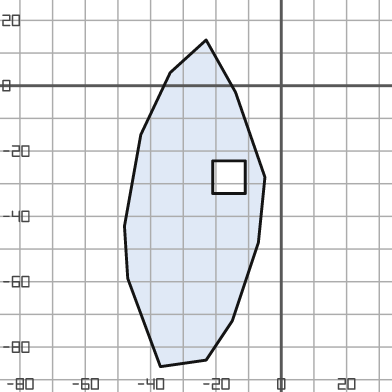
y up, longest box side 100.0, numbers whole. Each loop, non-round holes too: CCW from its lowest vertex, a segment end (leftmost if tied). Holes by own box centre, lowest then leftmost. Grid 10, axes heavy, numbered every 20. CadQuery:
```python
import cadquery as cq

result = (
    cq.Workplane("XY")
    .moveTo(-37.0, -86.0)
    .lineTo(-23.0, -84.0)
    .lineTo(-15.0, -72.0)
    .lineTo(-7.0, -48.0)
    .lineTo(-5.0, -28.0)
    .lineTo(-14.0, -2.0)
    .lineTo(-23.0, 14.0)
    .lineTo(-34.0, 4.0)
    .lineTo(-43.0, -15.0)
    .lineTo(-48.0, -43.0)
    .lineTo(-47.0, -59.0)
    .close()
    .moveTo(-21.0, -33.0)
    .lineTo(-11.0, -33.0)
    .lineTo(-11.0, -23.0)
    .lineTo(-21.0, -23.0)
    .close()
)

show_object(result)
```